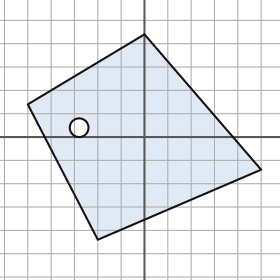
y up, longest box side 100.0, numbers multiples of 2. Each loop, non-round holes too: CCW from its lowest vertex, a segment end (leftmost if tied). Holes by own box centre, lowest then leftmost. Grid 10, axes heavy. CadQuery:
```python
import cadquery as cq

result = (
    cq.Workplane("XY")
    .moveTo(-20.0, -44.0)
    .lineTo(50.0, -14.0)
    .lineTo(0.0, 44.0)
    .lineTo(-50.0, 14.0)
    .close()
    .moveTo(-28.0, 4.0)
    .circle(4.0)
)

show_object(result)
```